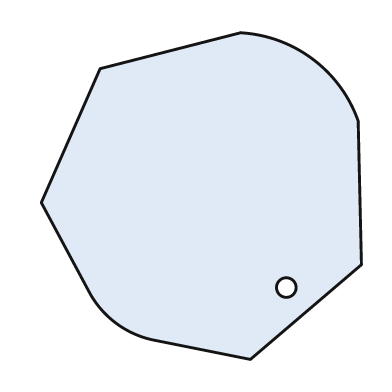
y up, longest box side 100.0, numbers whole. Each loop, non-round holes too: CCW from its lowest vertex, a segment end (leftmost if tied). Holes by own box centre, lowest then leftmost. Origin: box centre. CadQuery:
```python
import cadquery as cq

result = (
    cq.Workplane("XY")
    .moveTo(15.0, -50.0)
    .lineTo(49.0, -21.0)
    .lineTo(48.0, 23.0)
    .threePointArc((34.0, 42.0), (12.0, 50.0))
    .lineTo(-31.0, 39.0)
    .lineTo(-49.0, -2.0)
    .lineTo(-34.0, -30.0)
    .threePointArc((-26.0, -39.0), (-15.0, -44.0))
    .close()
    .moveTo(26.0, -28.0)
    .circle(3.0)
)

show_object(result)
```